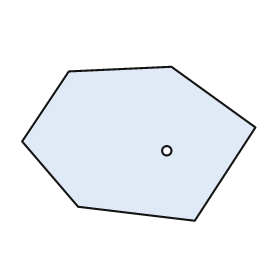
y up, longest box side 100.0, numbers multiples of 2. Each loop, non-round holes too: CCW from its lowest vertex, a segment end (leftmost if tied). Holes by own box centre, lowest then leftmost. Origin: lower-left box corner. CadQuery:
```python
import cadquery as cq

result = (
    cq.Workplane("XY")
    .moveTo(74.0, 0.0)
    .lineTo(100.0, 40.0)
    .lineTo(64.0, 66.0)
    .lineTo(20.0, 64.0)
    .lineTo(0.0, 34.0)
    .lineTo(24.0, 6.0)
    .close()
    .moveTo(62.0, 30.0)
    .circle(2.0)
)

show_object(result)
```